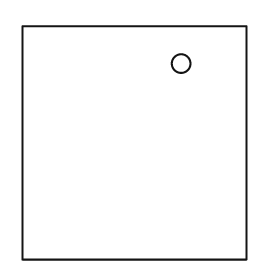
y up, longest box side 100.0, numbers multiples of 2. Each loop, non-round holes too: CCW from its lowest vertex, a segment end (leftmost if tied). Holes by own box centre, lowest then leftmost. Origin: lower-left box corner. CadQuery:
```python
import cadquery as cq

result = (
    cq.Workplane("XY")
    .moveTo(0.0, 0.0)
    .lineTo(96.0, 0.0)
    .lineTo(96.0, 100.0)
    .lineTo(0.0, 100.0)
    .close()
    .moveTo(68.0, 84.0)
    .circle(4.0)
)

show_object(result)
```